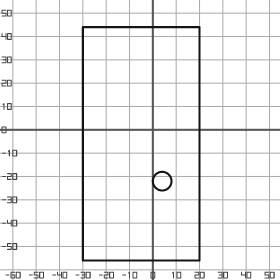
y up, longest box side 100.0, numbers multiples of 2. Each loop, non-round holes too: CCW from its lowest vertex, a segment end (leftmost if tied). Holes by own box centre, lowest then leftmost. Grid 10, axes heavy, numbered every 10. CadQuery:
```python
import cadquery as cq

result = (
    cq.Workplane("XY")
    .moveTo(-30.0, -56.0)
    .lineTo(20.0, -56.0)
    .lineTo(20.0, 44.0)
    .lineTo(-30.0, 44.0)
    .close()
    .moveTo(4.0, -22.0)
    .circle(4.0)
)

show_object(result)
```